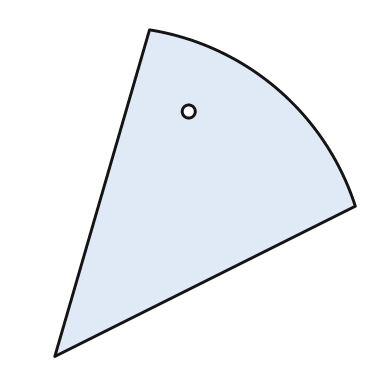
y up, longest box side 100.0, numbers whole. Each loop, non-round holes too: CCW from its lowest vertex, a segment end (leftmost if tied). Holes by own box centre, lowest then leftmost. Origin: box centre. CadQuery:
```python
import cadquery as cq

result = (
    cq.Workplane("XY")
    .moveTo(-46.0, -50.0)
    .lineTo(46.0, -4.0)
    .threePointArc((22.0, 32.0), (-17.0, 50.0))
    .close()
    .moveTo(-5.0, 25.0)
    .circle(2.0)
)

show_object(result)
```